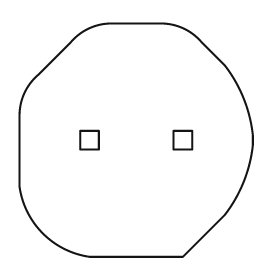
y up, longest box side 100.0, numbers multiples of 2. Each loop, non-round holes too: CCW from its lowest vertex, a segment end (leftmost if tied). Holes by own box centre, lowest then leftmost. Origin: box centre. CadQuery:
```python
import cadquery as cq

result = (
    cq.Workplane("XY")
    .moveTo(-20.0, -50.0)
    .lineTo(20.0, -50.0)
    .lineTo(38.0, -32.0)
    .threePointArc((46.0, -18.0), (50.0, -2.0))
    .lineTo(50.0, 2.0)
    .threePointArc((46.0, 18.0), (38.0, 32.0))
    .lineTo(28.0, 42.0)
    .threePointArc((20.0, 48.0), (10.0, 50.0))
    .lineTo(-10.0, 50.0)
    .threePointArc((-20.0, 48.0), (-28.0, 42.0))
    .lineTo(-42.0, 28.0)
    .threePointArc((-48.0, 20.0), (-50.0, 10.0))
    .lineTo(-50.0, -20.0)
    .threePointArc((-40.0, -40.0), (-20.0, -50.0))
    .close()
    .moveTo(-24.0, -4.0)
    .lineTo(-16.0, -4.0)
    .lineTo(-16.0, 4.0)
    .lineTo(-24.0, 4.0)
    .close()
    .moveTo(16.0, -4.0)
    .lineTo(24.0, -4.0)
    .lineTo(24.0, 4.0)
    .lineTo(16.0, 4.0)
    .close()
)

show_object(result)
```